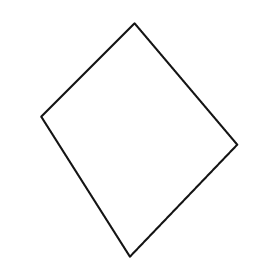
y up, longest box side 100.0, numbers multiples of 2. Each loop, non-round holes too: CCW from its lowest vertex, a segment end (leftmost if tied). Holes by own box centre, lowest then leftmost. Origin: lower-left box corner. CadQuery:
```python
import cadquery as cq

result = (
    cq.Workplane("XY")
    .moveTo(38.0, 0.0)
    .lineTo(84.0, 48.0)
    .lineTo(40.0, 100.0)
    .lineTo(0.0, 60.0)
    .close()
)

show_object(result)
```